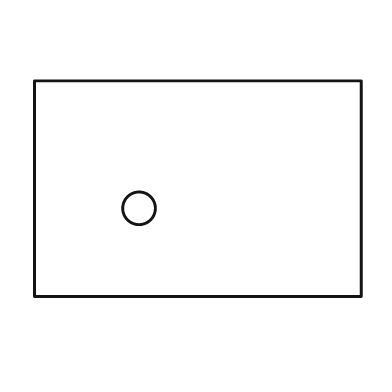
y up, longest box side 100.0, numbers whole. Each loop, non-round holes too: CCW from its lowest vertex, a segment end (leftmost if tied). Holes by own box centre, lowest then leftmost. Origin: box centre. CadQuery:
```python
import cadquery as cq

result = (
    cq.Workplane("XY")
    .moveTo(-50.0, -33.0)
    .lineTo(50.0, -33.0)
    .lineTo(50.0, 33.0)
    .lineTo(-50.0, 33.0)
    .close()
    .moveTo(-18.0, -6.0)
    .circle(5.0)
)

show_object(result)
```